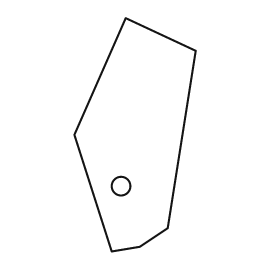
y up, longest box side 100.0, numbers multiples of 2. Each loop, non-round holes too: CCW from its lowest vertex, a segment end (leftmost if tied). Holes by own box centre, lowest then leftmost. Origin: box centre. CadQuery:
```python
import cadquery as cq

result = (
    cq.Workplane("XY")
    .moveTo(-10.0, -50.0)
    .lineTo(2.0, -48.0)
    .lineTo(14.0, -40.0)
    .lineTo(26.0, 36.0)
    .lineTo(-4.0, 50.0)
    .lineTo(-26.0, 0.0)
    .close()
    .moveTo(-6.0, -22.0)
    .circle(4.0)
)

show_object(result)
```